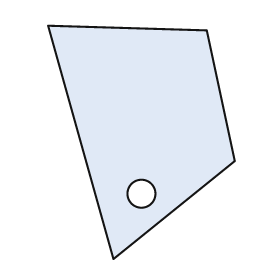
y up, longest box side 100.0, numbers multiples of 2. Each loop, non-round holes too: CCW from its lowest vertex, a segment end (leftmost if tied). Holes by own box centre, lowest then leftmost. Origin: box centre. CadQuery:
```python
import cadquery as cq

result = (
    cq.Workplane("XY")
    .moveTo(-12.0, -50.0)
    .lineTo(40.0, -8.0)
    .lineTo(28.0, 48.0)
    .lineTo(-40.0, 50.0)
    .close()
    .moveTo(0.0, -22.0)
    .circle(6.0)
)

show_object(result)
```